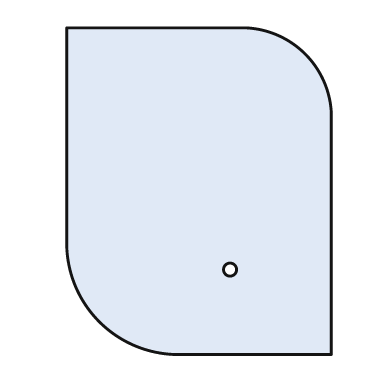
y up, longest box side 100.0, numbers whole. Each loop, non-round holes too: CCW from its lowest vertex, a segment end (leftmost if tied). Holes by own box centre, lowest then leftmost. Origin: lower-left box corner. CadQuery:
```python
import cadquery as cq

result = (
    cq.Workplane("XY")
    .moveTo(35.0, 0.0)
    .lineTo(81.0, 0.0)
    .lineTo(81.0, 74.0)
    .threePointArc((73.0, 92.0), (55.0, 100.0))
    .lineTo(0.0, 100.0)
    .lineTo(0.0, 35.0)
    .threePointArc((10.0, 10.0), (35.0, 0.0))
    .close()
    .moveTo(50.0, 26.0)
    .circle(2.0)
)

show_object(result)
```